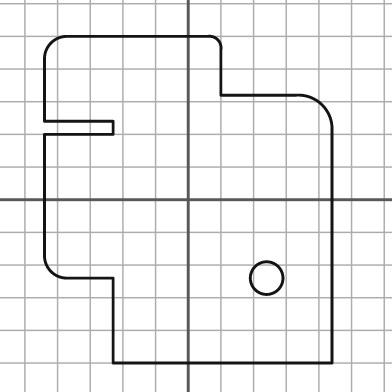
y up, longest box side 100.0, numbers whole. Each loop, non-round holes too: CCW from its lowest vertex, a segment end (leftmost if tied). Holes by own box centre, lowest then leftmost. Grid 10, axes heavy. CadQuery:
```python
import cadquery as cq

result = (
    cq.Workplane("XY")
    .moveTo(-23.0, -50.0)
    .lineTo(44.0, -50.0)
    .lineTo(44.0, 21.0)
    .threePointArc((41.0, 29.0), (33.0, 32.0))
    .lineTo(10.0, 32.0)
    .lineTo(10.0, 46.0)
    .threePointArc((9.0, 49.0), (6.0, 50.0))
    .lineTo(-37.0, 50.0)
    .threePointArc((-42.0, 48.0), (-44.0, 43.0))
    .lineTo(-44.0, 24.0)
    .lineTo(-23.0, 24.0)
    .lineTo(-23.0, 20.0)
    .lineTo(-44.0, 20.0)
    .lineTo(-44.0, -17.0)
    .threePointArc((-42.0, -22.0), (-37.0, -24.0))
    .lineTo(-23.0, -24.0)
    .close()
    .moveTo(24.0, -24.0)
    .circle(5.0)
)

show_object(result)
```